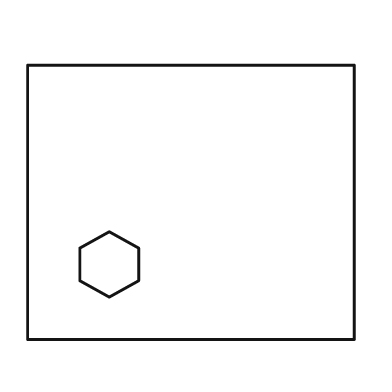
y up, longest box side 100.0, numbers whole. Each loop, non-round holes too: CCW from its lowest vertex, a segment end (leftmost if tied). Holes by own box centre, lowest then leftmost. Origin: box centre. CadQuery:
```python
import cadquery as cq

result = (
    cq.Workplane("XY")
    .moveTo(-50.0, -42.0)
    .lineTo(50.0, -42.0)
    .lineTo(50.0, 42.0)
    .lineTo(-50.0, 42.0)
    .close()
    .moveTo(-25.0, -29.0)
    .lineTo(-16.0, -24.0)
    .lineTo(-16.0, -14.0)
    .lineTo(-25.0, -9.0)
    .lineTo(-34.0, -14.0)
    .lineTo(-34.0, -24.0)
    .close()
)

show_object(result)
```